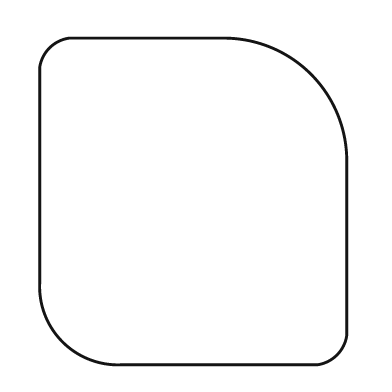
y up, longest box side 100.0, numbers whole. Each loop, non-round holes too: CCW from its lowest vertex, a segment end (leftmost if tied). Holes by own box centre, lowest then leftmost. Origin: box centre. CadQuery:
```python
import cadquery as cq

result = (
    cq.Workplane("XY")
    .moveTo(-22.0, -50.0)
    .lineTo(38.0, -50.0)
    .threePointArc((44.0, -47.0), (47.0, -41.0))
    .lineTo(47.0, 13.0)
    .threePointArc((36.0, 39.0), (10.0, 50.0))
    .lineTo(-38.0, 50.0)
    .threePointArc((-44.0, 47.0), (-47.0, 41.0))
    .lineTo(-47.0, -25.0)
    .threePointArc((-40.0, -43.0), (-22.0, -50.0))
    .close()
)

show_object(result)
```